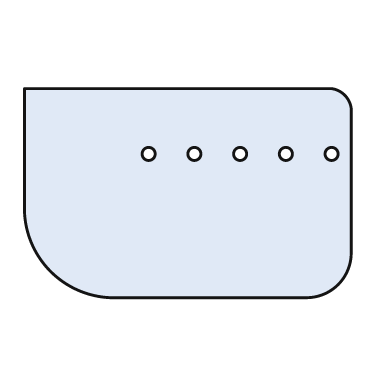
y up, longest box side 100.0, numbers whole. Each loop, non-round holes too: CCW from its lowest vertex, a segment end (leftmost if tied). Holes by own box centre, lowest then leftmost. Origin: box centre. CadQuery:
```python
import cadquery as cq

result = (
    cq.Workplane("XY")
    .moveTo(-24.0, -32.0)
    .lineTo(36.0, -32.0)
    .threePointArc((46.0, -28.0), (50.0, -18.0))
    .lineTo(50.0, 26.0)
    .threePointArc((48.0, 30.0), (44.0, 32.0))
    .lineTo(-50.0, 32.0)
    .lineTo(-50.0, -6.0)
    .threePointArc((-42.0, -24.0), (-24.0, -32.0))
    .close()
    .moveTo(-12.0, 12.0)
    .circle(2.0)
    .moveTo(2.0, 12.0)
    .circle(2.0)
    .moveTo(16.0, 12.0)
    .circle(2.0)
    .moveTo(30.0, 12.0)
    .circle(2.0)
    .moveTo(44.0, 12.0)
    .circle(2.0)
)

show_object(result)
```